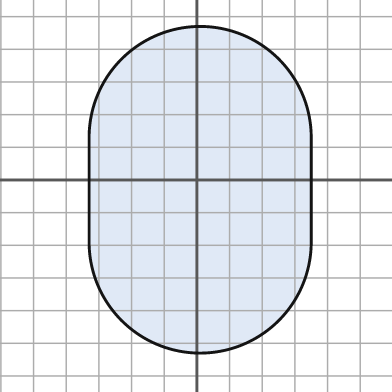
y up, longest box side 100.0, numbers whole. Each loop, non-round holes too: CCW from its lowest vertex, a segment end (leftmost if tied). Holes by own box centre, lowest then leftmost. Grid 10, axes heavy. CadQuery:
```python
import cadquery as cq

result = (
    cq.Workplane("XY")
    .moveTo(-33.0, -19.0)
    .threePointArc((1.0, -53.0), (35.0, -19.0))
    .lineTo(35.0, 13.0)
    .threePointArc((1.0, 47.0), (-33.0, 13.0))
    .close()
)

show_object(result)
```